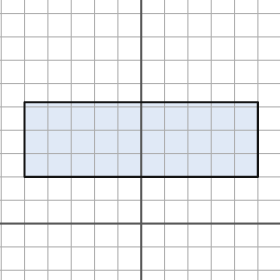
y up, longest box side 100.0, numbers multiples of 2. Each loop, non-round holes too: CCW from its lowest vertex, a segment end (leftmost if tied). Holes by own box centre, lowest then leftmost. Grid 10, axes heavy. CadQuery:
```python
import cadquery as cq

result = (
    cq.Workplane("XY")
    .moveTo(-50.0, 20.0)
    .lineTo(50.0, 20.0)
    .lineTo(50.0, 52.0)
    .lineTo(-50.0, 52.0)
    .close()
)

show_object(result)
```